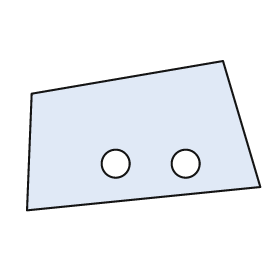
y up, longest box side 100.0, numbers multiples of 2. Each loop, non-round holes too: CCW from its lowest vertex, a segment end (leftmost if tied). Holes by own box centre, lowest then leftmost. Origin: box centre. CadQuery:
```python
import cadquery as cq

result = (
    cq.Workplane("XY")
    .moveTo(-50.0, -32.0)
    .lineTo(50.0, -22.0)
    .lineTo(34.0, 32.0)
    .lineTo(-48.0, 18.0)
    .close()
    .moveTo(-12.0, -12.0)
    .circle(6.0)
    .moveTo(18.0, -12.0)
    .circle(6.0)
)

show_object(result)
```